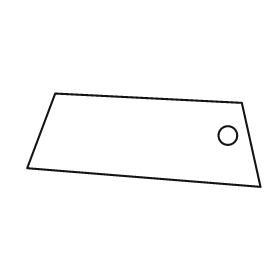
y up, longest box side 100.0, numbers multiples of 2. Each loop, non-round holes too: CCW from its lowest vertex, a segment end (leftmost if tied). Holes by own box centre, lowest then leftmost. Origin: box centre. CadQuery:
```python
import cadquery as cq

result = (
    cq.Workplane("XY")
    .moveTo(50.0, -20.0)
    .lineTo(42.0, 16.0)
    .lineTo(-38.0, 20.0)
    .lineTo(-50.0, -12.0)
    .close()
    .moveTo(36.0, 2.0)
    .circle(4.0)
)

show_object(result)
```